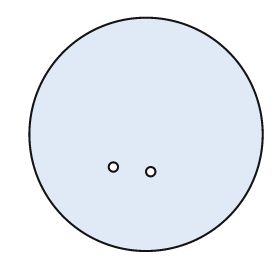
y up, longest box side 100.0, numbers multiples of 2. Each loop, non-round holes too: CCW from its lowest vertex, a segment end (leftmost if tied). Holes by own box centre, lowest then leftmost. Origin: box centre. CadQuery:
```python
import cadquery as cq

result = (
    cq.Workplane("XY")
    .moveTo(0.0, 0.0)
    .circle(50.0)
    .moveTo(2.0, -16.0)
    .circle(2.0)
    .moveTo(-14.0, -14.0)
    .circle(2.0)
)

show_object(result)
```